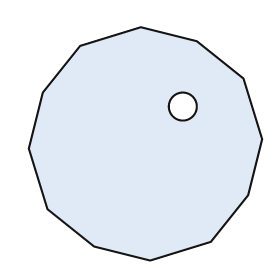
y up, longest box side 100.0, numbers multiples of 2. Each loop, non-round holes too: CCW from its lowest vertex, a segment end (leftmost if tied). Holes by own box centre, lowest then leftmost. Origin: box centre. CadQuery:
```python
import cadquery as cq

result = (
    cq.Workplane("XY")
    .moveTo(2.0, -50.0)
    .lineTo(28.0, -42.0)
    .lineTo(44.0, -22.0)
    .lineTo(50.0, 2.0)
    .lineTo(42.0, 28.0)
    .lineTo(22.0, 44.0)
    .lineTo(-2.0, 50.0)
    .lineTo(-28.0, 42.0)
    .lineTo(-44.0, 22.0)
    .lineTo(-50.0, -2.0)
    .lineTo(-42.0, -28.0)
    .lineTo(-22.0, -44.0)
    .close()
    .moveTo(16.0, 16.0)
    .circle(6.0)
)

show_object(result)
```